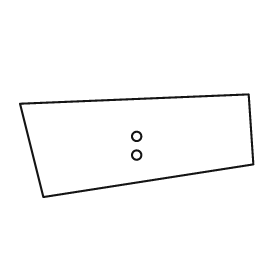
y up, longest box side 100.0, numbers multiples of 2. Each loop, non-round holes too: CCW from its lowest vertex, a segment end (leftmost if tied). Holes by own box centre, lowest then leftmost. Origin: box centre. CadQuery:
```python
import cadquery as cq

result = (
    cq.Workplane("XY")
    .moveTo(-40.0, -22.0)
    .lineTo(50.0, -8.0)
    .lineTo(48.0, 22.0)
    .lineTo(-50.0, 18.0)
    .close()
    .moveTo(0.0, -4.0)
    .circle(2.0)
    .moveTo(0.0, 4.0)
    .circle(2.0)
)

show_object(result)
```